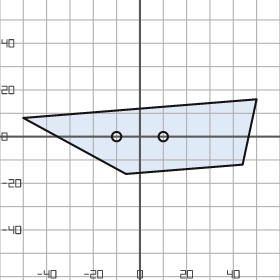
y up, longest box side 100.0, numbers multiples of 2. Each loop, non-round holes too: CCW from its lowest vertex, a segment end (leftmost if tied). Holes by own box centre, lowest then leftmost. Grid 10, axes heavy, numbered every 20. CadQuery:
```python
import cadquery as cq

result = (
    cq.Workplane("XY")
    .moveTo(-6.0, -16.0)
    .lineTo(44.0, -12.0)
    .lineTo(50.0, 16.0)
    .lineTo(-50.0, 8.0)
    .close()
    .moveTo(-10.0, 0.0)
    .circle(2.0)
    .moveTo(10.0, 0.0)
    .circle(2.0)
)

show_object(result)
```